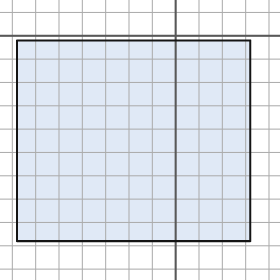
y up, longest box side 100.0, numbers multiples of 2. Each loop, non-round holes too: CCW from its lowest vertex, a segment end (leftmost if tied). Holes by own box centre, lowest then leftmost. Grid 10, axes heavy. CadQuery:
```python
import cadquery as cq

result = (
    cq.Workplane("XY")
    .moveTo(-68.0, -88.0)
    .lineTo(32.0, -88.0)
    .lineTo(32.0, -2.0)
    .lineTo(-68.0, -2.0)
    .close()
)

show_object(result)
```